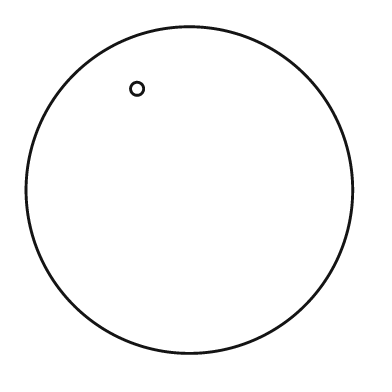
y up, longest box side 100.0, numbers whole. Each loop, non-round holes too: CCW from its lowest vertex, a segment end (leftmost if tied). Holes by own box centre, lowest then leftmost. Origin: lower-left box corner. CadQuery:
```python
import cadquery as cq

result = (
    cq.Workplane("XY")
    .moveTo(50.0, 50.0)
    .circle(50.0)
    .moveTo(34.0, 81.0)
    .circle(2.0)
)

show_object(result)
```